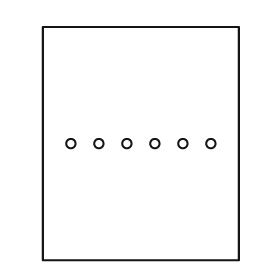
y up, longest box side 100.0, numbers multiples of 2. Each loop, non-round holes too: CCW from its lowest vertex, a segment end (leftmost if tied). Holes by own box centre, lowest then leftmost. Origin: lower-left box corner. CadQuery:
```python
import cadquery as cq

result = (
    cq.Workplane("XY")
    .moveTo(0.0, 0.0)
    .lineTo(84.0, 0.0)
    .lineTo(84.0, 100.0)
    .lineTo(0.0, 100.0)
    .close()
    .moveTo(12.0, 50.0)
    .circle(2.0)
    .moveTo(24.0, 50.0)
    .circle(2.0)
    .moveTo(36.0, 50.0)
    .circle(2.0)
    .moveTo(48.0, 50.0)
    .circle(2.0)
    .moveTo(60.0, 50.0)
    .circle(2.0)
    .moveTo(72.0, 50.0)
    .circle(2.0)
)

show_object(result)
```